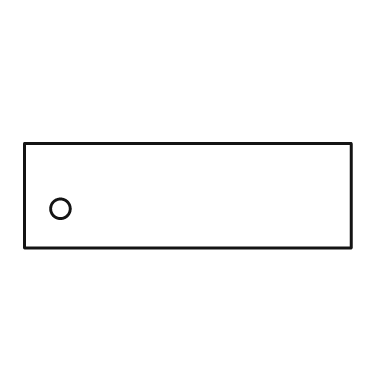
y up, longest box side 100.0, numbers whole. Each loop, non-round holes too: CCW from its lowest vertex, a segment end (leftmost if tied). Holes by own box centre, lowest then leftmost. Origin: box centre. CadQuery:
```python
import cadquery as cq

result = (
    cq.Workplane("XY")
    .moveTo(-50.0, -16.0)
    .lineTo(50.0, -16.0)
    .lineTo(50.0, 16.0)
    .lineTo(-50.0, 16.0)
    .close()
    .moveTo(-39.0, -4.0)
    .circle(3.0)
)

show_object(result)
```